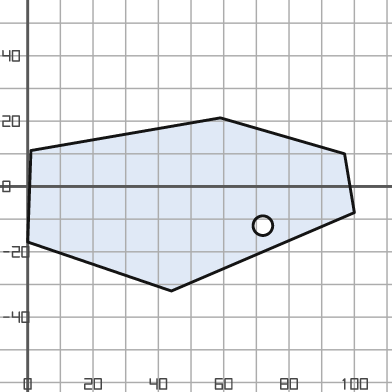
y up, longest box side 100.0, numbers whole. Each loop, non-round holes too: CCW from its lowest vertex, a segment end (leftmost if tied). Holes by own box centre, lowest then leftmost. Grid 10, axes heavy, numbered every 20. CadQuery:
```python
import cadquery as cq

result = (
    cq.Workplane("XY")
    .moveTo(44.0, -32.0)
    .lineTo(100.0, -8.0)
    .lineTo(97.0, 10.0)
    .lineTo(59.0, 21.0)
    .lineTo(1.0, 11.0)
    .lineTo(0.0, -17.0)
    .close()
    .moveTo(72.0, -12.0)
    .circle(3.0)
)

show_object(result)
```